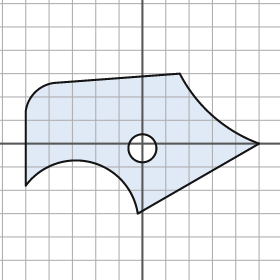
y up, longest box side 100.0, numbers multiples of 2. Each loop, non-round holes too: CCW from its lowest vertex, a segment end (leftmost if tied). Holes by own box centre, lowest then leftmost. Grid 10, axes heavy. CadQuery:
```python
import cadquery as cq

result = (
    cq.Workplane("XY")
    .moveTo(-2.0, -30.0)
    .lineTo(50.0, 0.0)
    .threePointArc((30.0, 12.0), (16.0, 30.0))
    .lineTo(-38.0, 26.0)
    .threePointArc((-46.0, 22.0), (-50.0, 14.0))
    .lineTo(-50.0, -18.0)
    .threePointArc((-22.0, -8.0), (-2.0, -30.0))
    .close()
    .moveTo(0.0, -2.0)
    .circle(6.0)
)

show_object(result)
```